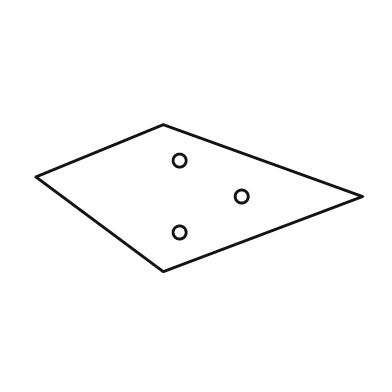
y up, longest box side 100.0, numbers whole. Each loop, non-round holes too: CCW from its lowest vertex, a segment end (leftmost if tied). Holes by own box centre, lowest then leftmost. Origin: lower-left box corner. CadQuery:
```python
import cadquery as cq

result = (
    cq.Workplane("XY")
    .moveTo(39.0, 0.0)
    .lineTo(100.0, 23.0)
    .lineTo(39.0, 45.0)
    .lineTo(0.0, 29.0)
    .close()
    .moveTo(44.0, 12.0)
    .circle(2.0)
    .moveTo(63.0, 23.0)
    .circle(2.0)
    .moveTo(44.0, 34.0)
    .circle(2.0)
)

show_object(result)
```